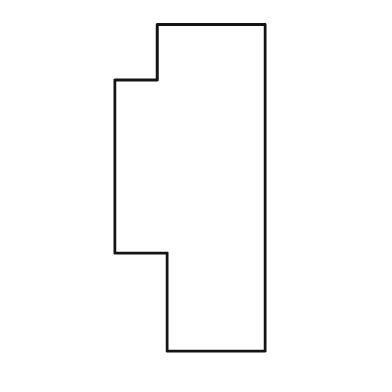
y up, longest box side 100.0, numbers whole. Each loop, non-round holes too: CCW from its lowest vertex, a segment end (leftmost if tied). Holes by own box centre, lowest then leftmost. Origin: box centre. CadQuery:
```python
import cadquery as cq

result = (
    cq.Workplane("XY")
    .moveTo(-7.0, -50.0)
    .lineTo(23.0, -50.0)
    .lineTo(23.0, 50.0)
    .lineTo(-10.0, 50.0)
    .lineTo(-10.0, 33.0)
    .lineTo(-23.0, 33.0)
    .lineTo(-23.0, -20.0)
    .lineTo(-7.0, -20.0)
    .close()
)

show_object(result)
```